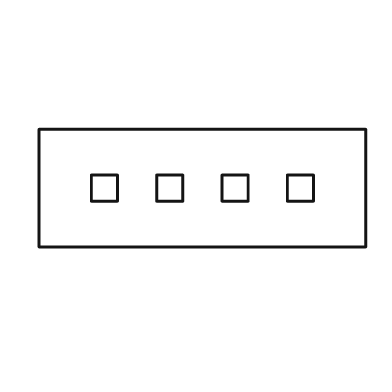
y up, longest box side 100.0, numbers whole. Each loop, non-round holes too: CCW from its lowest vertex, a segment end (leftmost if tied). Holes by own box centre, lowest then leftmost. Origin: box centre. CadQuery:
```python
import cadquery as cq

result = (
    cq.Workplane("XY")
    .moveTo(-50.0, -18.0)
    .lineTo(50.0, -18.0)
    .lineTo(50.0, 18.0)
    .lineTo(-50.0, 18.0)
    .close()
    .moveTo(-34.0, -4.0)
    .lineTo(-26.0, -4.0)
    .lineTo(-26.0, 4.0)
    .lineTo(-34.0, 4.0)
    .close()
    .moveTo(-14.0, -4.0)
    .lineTo(-6.0, -4.0)
    .lineTo(-6.0, 4.0)
    .lineTo(-14.0, 4.0)
    .close()
    .moveTo(6.0, -4.0)
    .lineTo(14.0, -4.0)
    .lineTo(14.0, 4.0)
    .lineTo(6.0, 4.0)
    .close()
    .moveTo(26.0, -4.0)
    .lineTo(34.0, -4.0)
    .lineTo(34.0, 4.0)
    .lineTo(26.0, 4.0)
    .close()
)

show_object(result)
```